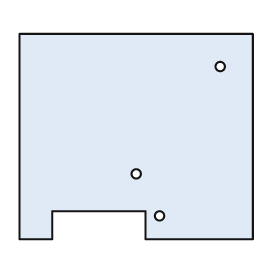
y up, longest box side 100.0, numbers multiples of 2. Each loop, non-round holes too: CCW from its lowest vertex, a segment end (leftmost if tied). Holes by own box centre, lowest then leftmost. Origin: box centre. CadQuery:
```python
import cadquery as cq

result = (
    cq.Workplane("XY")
    .moveTo(-50.0, -44.0)
    .lineTo(-36.0, -44.0)
    .lineTo(-36.0, -32.0)
    .lineTo(4.0, -32.0)
    .lineTo(4.0, -44.0)
    .lineTo(50.0, -44.0)
    .lineTo(50.0, 44.0)
    .lineTo(-50.0, 44.0)
    .close()
    .moveTo(10.0, -34.0)
    .circle(2.0)
    .moveTo(0.0, -16.0)
    .circle(2.0)
    .moveTo(36.0, 30.0)
    .circle(2.0)
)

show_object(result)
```